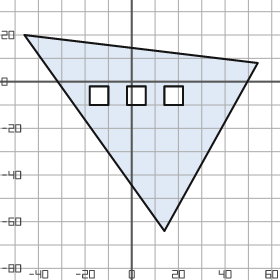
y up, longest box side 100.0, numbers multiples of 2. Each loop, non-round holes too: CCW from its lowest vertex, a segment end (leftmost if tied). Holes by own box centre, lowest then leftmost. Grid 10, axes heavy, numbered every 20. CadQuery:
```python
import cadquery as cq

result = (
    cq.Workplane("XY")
    .moveTo(14.0, -64.0)
    .lineTo(54.0, 8.0)
    .lineTo(-46.0, 20.0)
    .close()
    .moveTo(-18.0, -10.0)
    .lineTo(-10.0, -10.0)
    .lineTo(-10.0, -2.0)
    .lineTo(-18.0, -2.0)
    .close()
    .moveTo(-2.0, -10.0)
    .lineTo(6.0, -10.0)
    .lineTo(6.0, -2.0)
    .lineTo(-2.0, -2.0)
    .close()
    .moveTo(14.0, -10.0)
    .lineTo(22.0, -10.0)
    .lineTo(22.0, -2.0)
    .lineTo(14.0, -2.0)
    .close()
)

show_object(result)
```